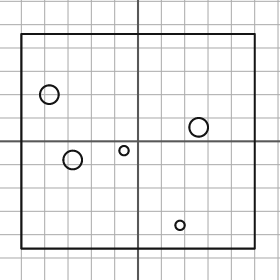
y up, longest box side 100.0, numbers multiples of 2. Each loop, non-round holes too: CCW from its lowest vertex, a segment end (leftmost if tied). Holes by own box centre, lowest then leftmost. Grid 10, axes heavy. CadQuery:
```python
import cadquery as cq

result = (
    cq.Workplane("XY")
    .moveTo(-50.0, -46.0)
    .lineTo(50.0, -46.0)
    .lineTo(50.0, 46.0)
    .lineTo(-50.0, 46.0)
    .close()
    .moveTo(18.0, -36.0)
    .circle(2.0)
    .moveTo(-28.0, -8.0)
    .circle(4.0)
    .moveTo(-6.0, -4.0)
    .circle(2.0)
    .moveTo(26.0, 6.0)
    .circle(4.0)
    .moveTo(-38.0, 20.0)
    .circle(4.0)
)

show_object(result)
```